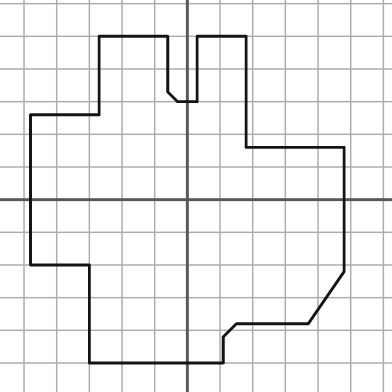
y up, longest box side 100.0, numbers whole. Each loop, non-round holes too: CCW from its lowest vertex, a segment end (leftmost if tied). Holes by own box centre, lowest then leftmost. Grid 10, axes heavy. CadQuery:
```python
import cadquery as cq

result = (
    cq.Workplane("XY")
    .moveTo(-30.0, -50.0)
    .lineTo(11.0, -50.0)
    .lineTo(11.0, -42.0)
    .lineTo(15.0, -38.0)
    .lineTo(37.0, -38.0)
    .lineTo(48.0, -22.0)
    .lineTo(48.0, 16.0)
    .lineTo(18.0, 16.0)
    .lineTo(18.0, 50.0)
    .lineTo(3.0, 50.0)
    .lineTo(3.0, 30.0)
    .lineTo(-3.0, 30.0)
    .lineTo(-6.0, 33.0)
    .lineTo(-6.0, 50.0)
    .lineTo(-27.0, 50.0)
    .lineTo(-27.0, 26.0)
    .lineTo(-48.0, 26.0)
    .lineTo(-48.0, -20.0)
    .lineTo(-30.0, -20.0)
    .close()
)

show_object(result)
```